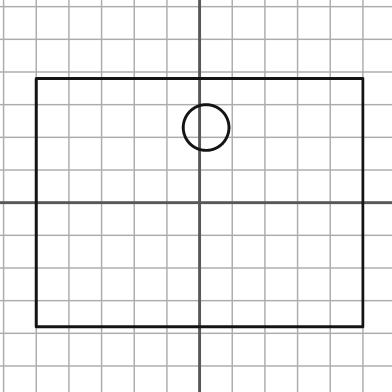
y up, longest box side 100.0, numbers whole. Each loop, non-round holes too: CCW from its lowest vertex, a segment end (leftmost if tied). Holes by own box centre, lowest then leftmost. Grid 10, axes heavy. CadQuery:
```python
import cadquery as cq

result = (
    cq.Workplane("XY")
    .moveTo(-50.0, -38.0)
    .lineTo(50.0, -38.0)
    .lineTo(50.0, 38.0)
    .lineTo(-50.0, 38.0)
    .close()
    .moveTo(2.0, 23.0)
    .circle(7.0)
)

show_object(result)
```